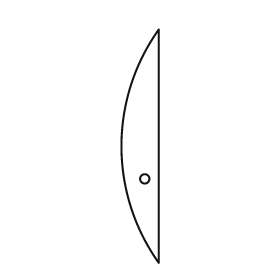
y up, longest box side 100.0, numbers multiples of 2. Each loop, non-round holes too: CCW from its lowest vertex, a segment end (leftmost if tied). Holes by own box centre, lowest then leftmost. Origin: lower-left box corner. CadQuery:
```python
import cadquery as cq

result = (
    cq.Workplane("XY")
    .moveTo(16.0, 0.0)
    .lineTo(16.0, 100.0)
    .threePointArc((0.0, 50.0), (16.0, 0.0))
    .close()
    .moveTo(10.0, 36.0)
    .circle(2.0)
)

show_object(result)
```